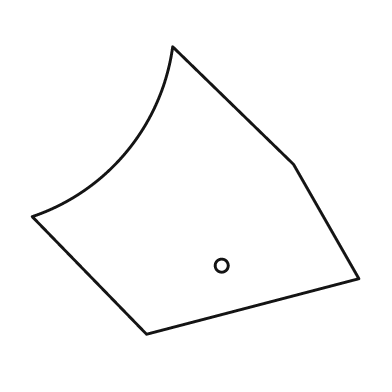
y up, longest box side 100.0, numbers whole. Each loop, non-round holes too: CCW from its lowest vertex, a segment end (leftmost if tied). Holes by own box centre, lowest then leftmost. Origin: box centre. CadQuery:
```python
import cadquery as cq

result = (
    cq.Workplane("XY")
    .moveTo(-15.0, -44.0)
    .lineTo(50.0, -27.0)
    .lineTo(30.0, 8.0)
    .lineTo(-7.0, 44.0)
    .threePointArc((-21.0, 12.0), (-50.0, -8.0))
    .close()
    .moveTo(8.0, -23.0)
    .circle(2.0)
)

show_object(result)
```